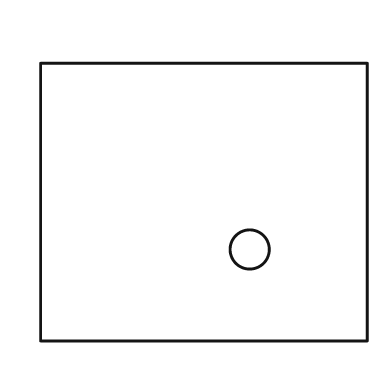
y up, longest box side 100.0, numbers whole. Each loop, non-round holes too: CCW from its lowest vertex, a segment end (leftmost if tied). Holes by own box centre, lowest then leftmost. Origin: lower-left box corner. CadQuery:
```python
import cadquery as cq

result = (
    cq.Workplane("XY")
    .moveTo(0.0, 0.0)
    .lineTo(100.0, 0.0)
    .lineTo(100.0, 85.0)
    .lineTo(0.0, 85.0)
    .close()
    .moveTo(64.0, 28.0)
    .circle(6.0)
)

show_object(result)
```